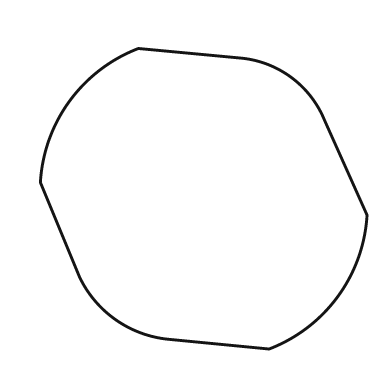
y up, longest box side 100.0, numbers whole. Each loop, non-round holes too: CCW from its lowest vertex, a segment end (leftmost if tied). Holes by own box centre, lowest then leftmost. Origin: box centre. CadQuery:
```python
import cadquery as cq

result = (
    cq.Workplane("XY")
    .moveTo(20.0, -46.0)
    .threePointArc((41.0, -30.0), (50.0, -5.0))
    .lineTo(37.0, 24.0)
    .threePointArc((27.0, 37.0), (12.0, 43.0))
    .lineTo(-20.0, 46.0)
    .threePointArc((-41.0, 30.0), (-50.0, 5.0))
    .lineTo(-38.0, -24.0)
    .threePointArc((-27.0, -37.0), (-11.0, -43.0))
    .close()
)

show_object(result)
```